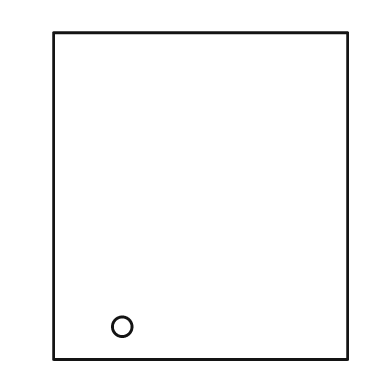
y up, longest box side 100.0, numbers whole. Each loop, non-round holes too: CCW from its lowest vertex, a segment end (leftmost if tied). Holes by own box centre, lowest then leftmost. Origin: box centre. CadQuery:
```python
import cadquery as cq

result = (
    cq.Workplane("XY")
    .moveTo(-45.0, -50.0)
    .lineTo(45.0, -50.0)
    .lineTo(45.0, 50.0)
    .lineTo(-45.0, 50.0)
    .close()
    .moveTo(-24.0, -40.0)
    .circle(3.0)
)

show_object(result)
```